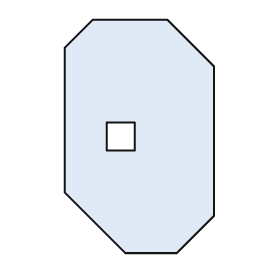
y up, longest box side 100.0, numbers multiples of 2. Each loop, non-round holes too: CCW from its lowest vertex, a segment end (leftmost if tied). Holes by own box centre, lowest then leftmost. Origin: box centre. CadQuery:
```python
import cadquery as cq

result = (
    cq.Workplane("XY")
    .moveTo(-6.0, -50.0)
    .lineTo(16.0, -50.0)
    .lineTo(32.0, -34.0)
    .lineTo(32.0, 30.0)
    .lineTo(12.0, 50.0)
    .lineTo(-20.0, 50.0)
    .lineTo(-32.0, 38.0)
    .lineTo(-32.0, -24.0)
    .close()
    .moveTo(-14.0, -6.0)
    .lineTo(-2.0, -6.0)
    .lineTo(-2.0, 6.0)
    .lineTo(-14.0, 6.0)
    .close()
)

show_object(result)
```